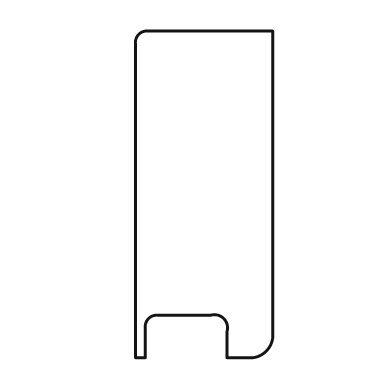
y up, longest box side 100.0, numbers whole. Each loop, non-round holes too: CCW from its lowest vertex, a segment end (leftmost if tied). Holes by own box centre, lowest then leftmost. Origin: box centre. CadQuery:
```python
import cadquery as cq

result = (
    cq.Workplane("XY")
    .moveTo(-21.0, -50.0)
    .lineTo(-18.0, -50.0)
    .lineTo(-18.0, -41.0)
    .threePointArc((-17.0, -38.0), (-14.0, -37.0))
    .lineTo(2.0, -37.0)
    .threePointArc((6.0, -38.0), (7.0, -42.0))
    .lineTo(7.0, -50.0)
    .lineTo(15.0, -50.0)
    .threePointArc((19.0, -48.0), (21.0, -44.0))
    .lineTo(21.0, 50.0)
    .lineTo(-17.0, 50.0)
    .threePointArc((-20.0, 49.0), (-21.0, 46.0))
    .close()
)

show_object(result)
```